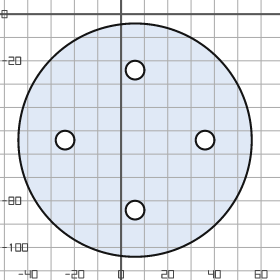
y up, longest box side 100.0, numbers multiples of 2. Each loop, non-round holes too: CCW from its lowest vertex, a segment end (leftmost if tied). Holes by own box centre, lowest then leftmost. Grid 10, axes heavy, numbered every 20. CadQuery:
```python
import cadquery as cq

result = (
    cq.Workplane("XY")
    .moveTo(6.0, -54.0)
    .circle(50.0)
    .moveTo(6.0, -84.0)
    .circle(4.0)
    .moveTo(-24.0, -54.0)
    .circle(4.0)
    .moveTo(36.0, -54.0)
    .circle(4.0)
    .moveTo(6.0, -24.0)
    .circle(4.0)
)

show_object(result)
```